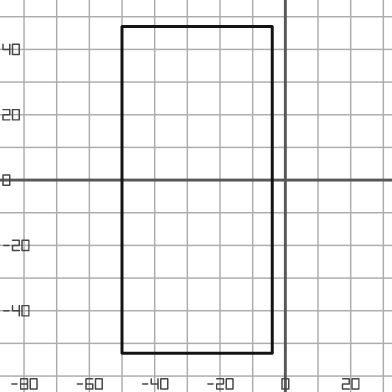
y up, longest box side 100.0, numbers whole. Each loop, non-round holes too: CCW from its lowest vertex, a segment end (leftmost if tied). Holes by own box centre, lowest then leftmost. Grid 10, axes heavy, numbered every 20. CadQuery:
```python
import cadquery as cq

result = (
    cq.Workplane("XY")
    .moveTo(-50.0, -53.0)
    .lineTo(-4.0, -53.0)
    .lineTo(-4.0, 47.0)
    .lineTo(-50.0, 47.0)
    .close()
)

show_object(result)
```